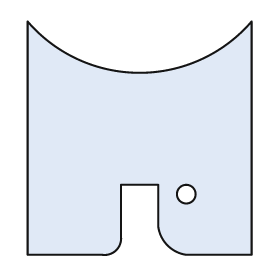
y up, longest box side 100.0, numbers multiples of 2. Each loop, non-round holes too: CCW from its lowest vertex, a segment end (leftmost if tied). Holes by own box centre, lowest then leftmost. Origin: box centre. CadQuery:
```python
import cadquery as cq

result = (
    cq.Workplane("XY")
    .moveTo(-48.0, -50.0)
    .lineTo(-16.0, -50.0)
    .threePointArc((-10.0, -48.0), (-8.0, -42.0))
    .lineTo(-8.0, -20.0)
    .lineTo(8.0, -20.0)
    .lineTo(8.0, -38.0)
    .threePointArc((12.0, -46.0), (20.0, -50.0))
    .lineTo(48.0, -50.0)
    .lineTo(48.0, 50.0)
    .threePointArc((0.0, 28.0), (-48.0, 50.0))
    .close()
    .moveTo(20.0, -24.0)
    .circle(4.0)
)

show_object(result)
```